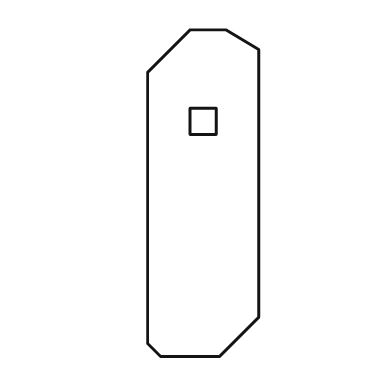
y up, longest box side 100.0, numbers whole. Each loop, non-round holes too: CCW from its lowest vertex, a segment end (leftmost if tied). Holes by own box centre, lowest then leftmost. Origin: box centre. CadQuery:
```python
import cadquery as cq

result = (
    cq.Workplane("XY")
    .moveTo(-13.0, -50.0)
    .lineTo(5.0, -50.0)
    .lineTo(17.0, -38.0)
    .lineTo(17.0, 44.0)
    .lineTo(7.0, 50.0)
    .lineTo(-4.0, 50.0)
    .lineTo(-17.0, 37.0)
    .lineTo(-17.0, -46.0)
    .close()
    .moveTo(-4.0, 18.0)
    .lineTo(4.0, 18.0)
    .lineTo(4.0, 26.0)
    .lineTo(-4.0, 26.0)
    .close()
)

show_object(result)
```